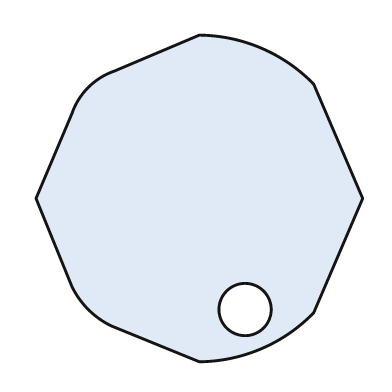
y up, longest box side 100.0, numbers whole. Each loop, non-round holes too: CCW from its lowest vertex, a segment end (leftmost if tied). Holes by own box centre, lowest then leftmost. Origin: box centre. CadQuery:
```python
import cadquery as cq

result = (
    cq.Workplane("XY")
    .moveTo(0.0, -50.0)
    .threePointArc((19.0, -46.0), (35.0, -35.0))
    .lineTo(50.0, 0.0)
    .lineTo(35.0, 35.0)
    .threePointArc((19.0, 46.0), (0.0, 50.0))
    .lineTo(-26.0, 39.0)
    .threePointArc((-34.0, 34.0), (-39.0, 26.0))
    .lineTo(-50.0, 0.0)
    .lineTo(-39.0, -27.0)
    .threePointArc((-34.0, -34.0), (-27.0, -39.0))
    .close()
    .moveTo(14.0, -34.0)
    .circle(8.0)
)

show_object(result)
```